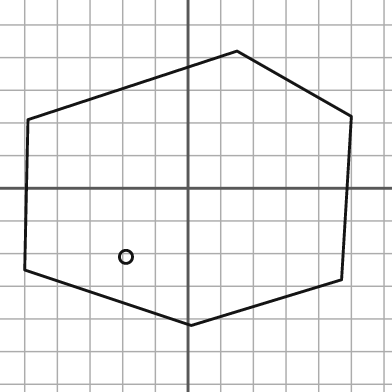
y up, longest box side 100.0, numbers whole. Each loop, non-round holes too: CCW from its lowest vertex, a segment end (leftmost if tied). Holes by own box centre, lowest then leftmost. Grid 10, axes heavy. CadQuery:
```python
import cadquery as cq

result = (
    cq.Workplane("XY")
    .moveTo(1.0, -42.0)
    .lineTo(47.0, -28.0)
    .lineTo(50.0, 22.0)
    .lineTo(15.0, 42.0)
    .lineTo(-49.0, 21.0)
    .lineTo(-50.0, -25.0)
    .close()
    .moveTo(-19.0, -21.0)
    .circle(2.0)
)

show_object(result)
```